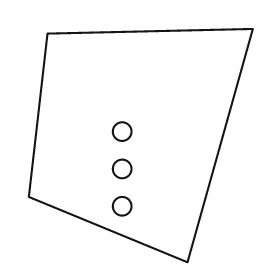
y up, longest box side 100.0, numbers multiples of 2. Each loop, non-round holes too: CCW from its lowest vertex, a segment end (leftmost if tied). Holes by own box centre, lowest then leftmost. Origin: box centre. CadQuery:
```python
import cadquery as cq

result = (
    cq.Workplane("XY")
    .moveTo(20.0, -50.0)
    .lineTo(48.0, 50.0)
    .lineTo(-40.0, 48.0)
    .lineTo(-48.0, -22.0)
    .close()
    .moveTo(-8.0, -26.0)
    .circle(4.0)
    .moveTo(-8.0, -10.0)
    .circle(4.0)
    .moveTo(-8.0, 6.0)
    .circle(4.0)
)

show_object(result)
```